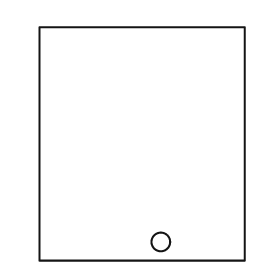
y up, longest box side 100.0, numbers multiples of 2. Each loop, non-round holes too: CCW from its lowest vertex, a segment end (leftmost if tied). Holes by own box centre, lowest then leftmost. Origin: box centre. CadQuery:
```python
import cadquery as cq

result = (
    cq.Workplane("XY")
    .moveTo(-44.0, -50.0)
    .lineTo(44.0, -50.0)
    .lineTo(44.0, 50.0)
    .lineTo(-44.0, 50.0)
    .close()
    .moveTo(8.0, -42.0)
    .circle(4.0)
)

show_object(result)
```